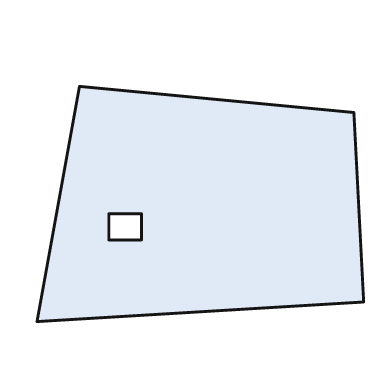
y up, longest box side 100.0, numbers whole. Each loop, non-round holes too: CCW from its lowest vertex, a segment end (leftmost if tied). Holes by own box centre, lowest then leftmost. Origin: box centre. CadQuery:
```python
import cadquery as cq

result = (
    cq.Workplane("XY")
    .moveTo(-50.0, -36.0)
    .lineTo(50.0, -30.0)
    .lineTo(47.0, 28.0)
    .lineTo(-37.0, 36.0)
    .close()
    .moveTo(-28.0, -11.0)
    .lineTo(-18.0, -11.0)
    .lineTo(-18.0, -3.0)
    .lineTo(-28.0, -3.0)
    .close()
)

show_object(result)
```